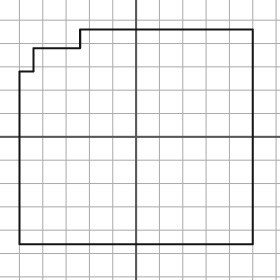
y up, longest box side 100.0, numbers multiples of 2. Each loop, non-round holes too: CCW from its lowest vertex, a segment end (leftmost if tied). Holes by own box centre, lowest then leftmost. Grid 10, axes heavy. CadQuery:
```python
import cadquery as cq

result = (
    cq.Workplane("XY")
    .moveTo(-50.0, -46.0)
    .lineTo(50.0, -46.0)
    .lineTo(50.0, 46.0)
    .lineTo(-24.0, 46.0)
    .lineTo(-24.0, 38.0)
    .lineTo(-44.0, 38.0)
    .lineTo(-44.0, 28.0)
    .lineTo(-50.0, 28.0)
    .close()
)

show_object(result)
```